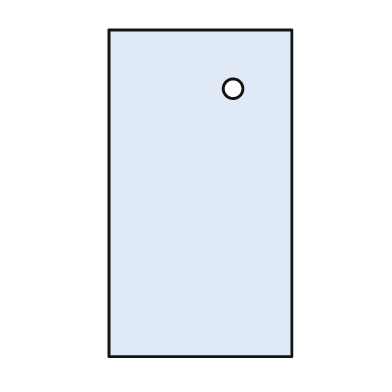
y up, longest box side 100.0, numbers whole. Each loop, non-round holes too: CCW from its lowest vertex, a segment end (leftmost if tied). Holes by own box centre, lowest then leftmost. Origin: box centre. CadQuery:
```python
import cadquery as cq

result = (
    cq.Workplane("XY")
    .moveTo(-28.0, -50.0)
    .lineTo(28.0, -50.0)
    .lineTo(28.0, 50.0)
    .lineTo(-28.0, 50.0)
    .close()
    .moveTo(10.0, 32.0)
    .circle(3.0)
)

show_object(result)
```